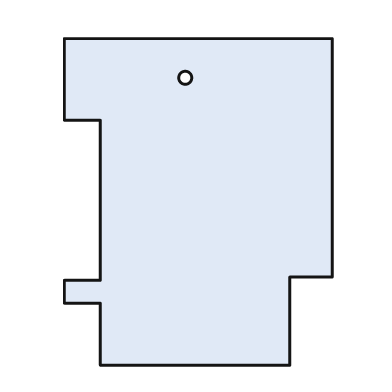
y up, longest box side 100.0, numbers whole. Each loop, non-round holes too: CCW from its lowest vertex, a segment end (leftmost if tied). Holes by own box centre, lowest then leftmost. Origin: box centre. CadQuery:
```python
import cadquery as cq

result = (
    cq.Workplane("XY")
    .moveTo(-30.0, -50.0)
    .lineTo(28.0, -50.0)
    .lineTo(28.0, -23.0)
    .lineTo(41.0, -23.0)
    .lineTo(41.0, 50.0)
    .lineTo(-41.0, 50.0)
    .lineTo(-41.0, 25.0)
    .lineTo(-30.0, 25.0)
    .lineTo(-30.0, -24.0)
    .lineTo(-41.0, -24.0)
    .lineTo(-41.0, -31.0)
    .lineTo(-30.0, -31.0)
    .close()
    .moveTo(-4.0, 38.0)
    .circle(2.0)
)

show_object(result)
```